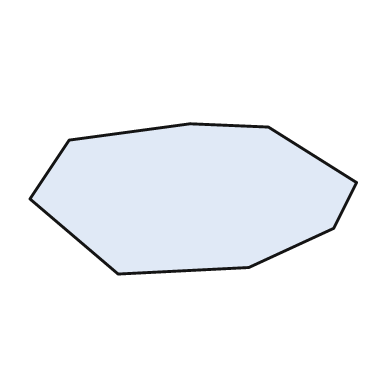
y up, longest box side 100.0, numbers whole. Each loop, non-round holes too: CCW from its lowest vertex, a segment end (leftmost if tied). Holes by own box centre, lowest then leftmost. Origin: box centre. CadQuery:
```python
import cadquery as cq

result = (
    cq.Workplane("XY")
    .moveTo(-23.0, -23.0)
    .lineTo(17.0, -21.0)
    .lineTo(43.0, -9.0)
    .lineTo(50.0, 5.0)
    .lineTo(23.0, 22.0)
    .lineTo(-1.0, 23.0)
    .lineTo(-38.0, 18.0)
    .lineTo(-50.0, 0.0)
    .close()
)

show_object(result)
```